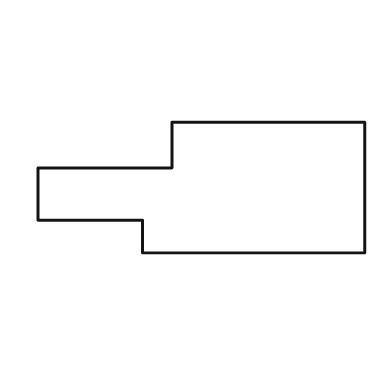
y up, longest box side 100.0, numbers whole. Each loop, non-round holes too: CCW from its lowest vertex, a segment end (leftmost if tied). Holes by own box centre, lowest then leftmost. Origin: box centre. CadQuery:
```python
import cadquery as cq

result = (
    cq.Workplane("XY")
    .moveTo(-18.0, -20.0)
    .lineTo(50.0, -20.0)
    .lineTo(50.0, 20.0)
    .lineTo(-9.0, 20.0)
    .lineTo(-9.0, 6.0)
    .lineTo(-50.0, 6.0)
    .lineTo(-50.0, -10.0)
    .lineTo(-18.0, -10.0)
    .close()
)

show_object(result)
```